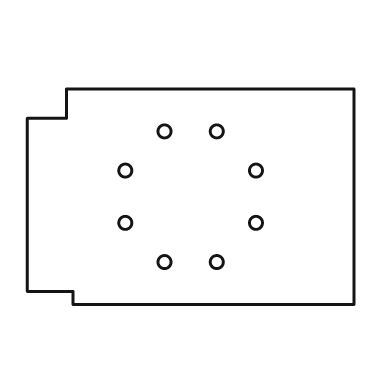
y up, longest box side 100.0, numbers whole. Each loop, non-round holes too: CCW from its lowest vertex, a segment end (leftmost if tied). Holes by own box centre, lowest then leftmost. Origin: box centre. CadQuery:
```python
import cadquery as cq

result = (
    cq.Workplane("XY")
    .moveTo(-36.0, -33.0)
    .lineTo(50.0, -33.0)
    .lineTo(50.0, 33.0)
    .lineTo(-38.0, 33.0)
    .lineTo(-38.0, 24.0)
    .lineTo(-50.0, 24.0)
    .lineTo(-50.0, -29.0)
    .lineTo(-36.0, -29.0)
    .close()
    .moveTo(-8.0, -20.0)
    .circle(2.0)
    .moveTo(8.0, -20.0)
    .circle(2.0)
    .moveTo(-20.0, -8.0)
    .circle(2.0)
    .moveTo(20.0, -8.0)
    .circle(2.0)
    .moveTo(-20.0, 8.0)
    .circle(2.0)
    .moveTo(20.0, 8.0)
    .circle(2.0)
    .moveTo(-8.0, 20.0)
    .circle(2.0)
    .moveTo(8.0, 20.0)
    .circle(2.0)
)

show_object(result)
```